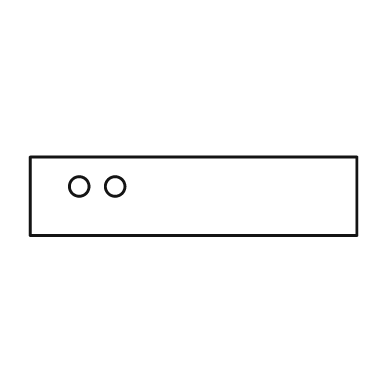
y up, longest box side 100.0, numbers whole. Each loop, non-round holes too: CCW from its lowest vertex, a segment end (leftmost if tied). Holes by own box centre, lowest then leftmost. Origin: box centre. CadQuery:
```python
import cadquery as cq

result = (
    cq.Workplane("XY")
    .moveTo(-50.0, -12.0)
    .lineTo(50.0, -12.0)
    .lineTo(50.0, 12.0)
    .lineTo(-50.0, 12.0)
    .close()
    .moveTo(-35.0, 3.0)
    .circle(3.0)
    .moveTo(-24.0, 3.0)
    .circle(3.0)
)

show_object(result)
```